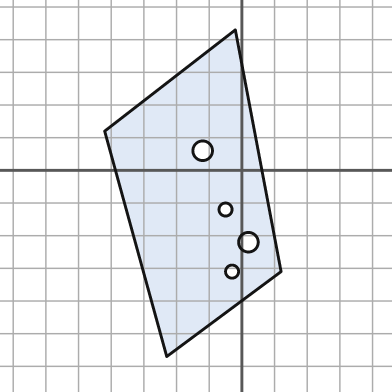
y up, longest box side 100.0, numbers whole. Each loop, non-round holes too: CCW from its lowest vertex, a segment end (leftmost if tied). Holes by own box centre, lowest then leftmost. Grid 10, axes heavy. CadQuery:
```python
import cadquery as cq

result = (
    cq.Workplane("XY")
    .moveTo(-23.0, -57.0)
    .lineTo(12.0, -31.0)
    .lineTo(-2.0, 43.0)
    .lineTo(-42.0, 12.0)
    .close()
    .moveTo(-3.0, -31.0)
    .circle(2.0)
    .moveTo(2.0, -22.0)
    .circle(3.0)
    .moveTo(-5.0, -12.0)
    .circle(2.0)
    .moveTo(-12.0, 6.0)
    .circle(3.0)
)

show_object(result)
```